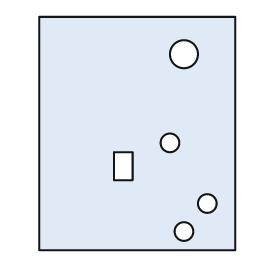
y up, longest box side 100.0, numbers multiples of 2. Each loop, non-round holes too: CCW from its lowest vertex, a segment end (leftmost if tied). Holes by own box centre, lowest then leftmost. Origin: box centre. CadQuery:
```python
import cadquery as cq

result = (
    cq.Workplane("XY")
    .moveTo(-42.0, -50.0)
    .lineTo(42.0, -50.0)
    .lineTo(42.0, 50.0)
    .lineTo(-42.0, 50.0)
    .close()
    .moveTo(20.0, -42.0)
    .circle(4.0)
    .moveTo(30.0, -30.0)
    .circle(4.0)
    .moveTo(-10.0, -20.0)
    .lineTo(-2.0, -20.0)
    .lineTo(-2.0, -8.0)
    .lineTo(-10.0, -8.0)
    .close()
    .moveTo(14.0, -4.0)
    .circle(4.0)
    .moveTo(20.0, 34.0)
    .circle(6.0)
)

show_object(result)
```